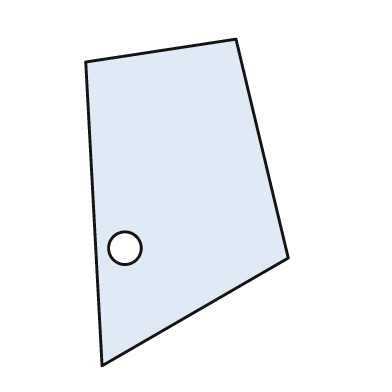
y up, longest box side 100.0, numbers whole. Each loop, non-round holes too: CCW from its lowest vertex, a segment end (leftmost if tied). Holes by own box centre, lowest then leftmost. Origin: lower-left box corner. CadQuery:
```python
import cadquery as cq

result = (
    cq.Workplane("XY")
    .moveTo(5.0, 0.0)
    .lineTo(62.0, 33.0)
    .lineTo(46.0, 100.0)
    .lineTo(0.0, 93.0)
    .close()
    .moveTo(12.0, 36.0)
    .circle(5.0)
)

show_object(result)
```